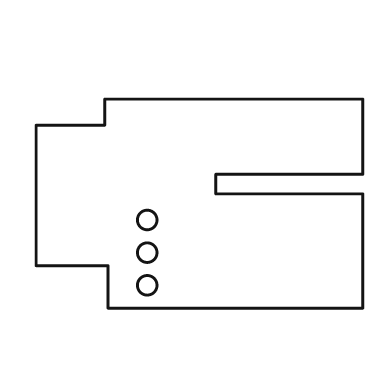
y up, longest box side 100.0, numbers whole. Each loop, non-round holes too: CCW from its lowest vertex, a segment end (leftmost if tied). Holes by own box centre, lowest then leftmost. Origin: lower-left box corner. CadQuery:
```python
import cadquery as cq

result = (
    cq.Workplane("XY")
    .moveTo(22.0, 0.0)
    .lineTo(100.0, 0.0)
    .lineTo(100.0, 35.0)
    .lineTo(55.0, 35.0)
    .lineTo(55.0, 41.0)
    .lineTo(100.0, 41.0)
    .lineTo(100.0, 64.0)
    .lineTo(21.0, 64.0)
    .lineTo(21.0, 56.0)
    .lineTo(0.0, 56.0)
    .lineTo(0.0, 13.0)
    .lineTo(22.0, 13.0)
    .close()
    .moveTo(34.0, 7.0)
    .circle(3.0)
    .moveTo(34.0, 17.0)
    .circle(3.0)
    .moveTo(34.0, 27.0)
    .circle(3.0)
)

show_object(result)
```